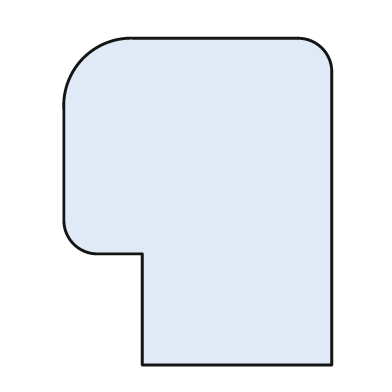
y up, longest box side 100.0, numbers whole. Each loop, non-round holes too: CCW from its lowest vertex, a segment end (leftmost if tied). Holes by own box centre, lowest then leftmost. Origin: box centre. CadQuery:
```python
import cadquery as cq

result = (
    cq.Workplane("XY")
    .moveTo(-17.0, -50.0)
    .lineTo(41.0, -50.0)
    .lineTo(41.0, 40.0)
    .threePointArc((38.0, 47.0), (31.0, 50.0))
    .lineTo(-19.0, 50.0)
    .threePointArc((-35.0, 44.0), (-41.0, 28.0))
    .lineTo(-41.0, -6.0)
    .threePointArc((-38.0, -13.0), (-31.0, -16.0))
    .lineTo(-17.0, -16.0)
    .close()
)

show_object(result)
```